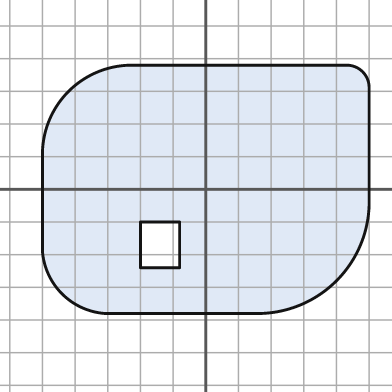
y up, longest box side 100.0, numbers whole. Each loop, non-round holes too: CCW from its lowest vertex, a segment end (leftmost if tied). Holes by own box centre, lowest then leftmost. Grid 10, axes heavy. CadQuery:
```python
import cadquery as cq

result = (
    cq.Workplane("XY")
    .moveTo(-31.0, -38.0)
    .lineTo(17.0, -38.0)
    .threePointArc((40.0, -28.0), (50.0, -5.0))
    .lineTo(50.0, 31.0)
    .threePointArc((48.0, 36.0), (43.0, 38.0))
    .lineTo(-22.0, 38.0)
    .threePointArc((-42.0, 30.0), (-50.0, 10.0))
    .lineTo(-50.0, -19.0)
    .threePointArc((-44.0, -32.0), (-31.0, -38.0))
    .close()
    .moveTo(-20.0, -24.0)
    .lineTo(-8.0, -24.0)
    .lineTo(-8.0, -10.0)
    .lineTo(-20.0, -10.0)
    .close()
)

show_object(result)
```